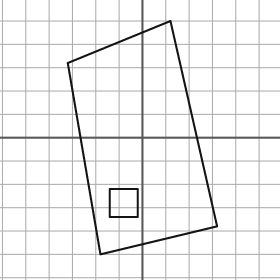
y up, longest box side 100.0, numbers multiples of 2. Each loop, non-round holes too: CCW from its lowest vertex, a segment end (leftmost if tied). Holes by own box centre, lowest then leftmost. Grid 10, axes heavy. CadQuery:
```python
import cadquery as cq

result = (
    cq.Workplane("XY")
    .moveTo(-18.0, -50.0)
    .lineTo(32.0, -38.0)
    .lineTo(12.0, 50.0)
    .lineTo(-32.0, 32.0)
    .close()
    .moveTo(-14.0, -34.0)
    .lineTo(-2.0, -34.0)
    .lineTo(-2.0, -22.0)
    .lineTo(-14.0, -22.0)
    .close()
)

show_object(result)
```